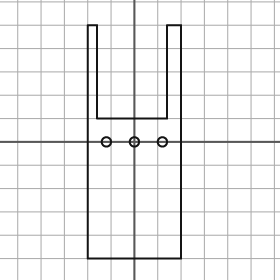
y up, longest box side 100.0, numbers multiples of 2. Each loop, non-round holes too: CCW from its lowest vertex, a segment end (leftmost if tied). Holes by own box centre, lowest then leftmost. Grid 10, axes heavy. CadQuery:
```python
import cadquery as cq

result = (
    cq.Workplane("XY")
    .moveTo(-20.0, -50.0)
    .lineTo(20.0, -50.0)
    .lineTo(20.0, 50.0)
    .lineTo(14.0, 50.0)
    .lineTo(14.0, 10.0)
    .lineTo(-16.0, 10.0)
    .lineTo(-16.0, 50.0)
    .lineTo(-20.0, 50.0)
    .close()
    .moveTo(-12.0, 0.0)
    .circle(2.0)
    .moveTo(0.0, 0.0)
    .circle(2.0)
    .moveTo(12.0, 0.0)
    .circle(2.0)
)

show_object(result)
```